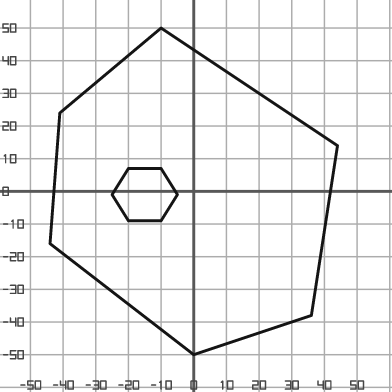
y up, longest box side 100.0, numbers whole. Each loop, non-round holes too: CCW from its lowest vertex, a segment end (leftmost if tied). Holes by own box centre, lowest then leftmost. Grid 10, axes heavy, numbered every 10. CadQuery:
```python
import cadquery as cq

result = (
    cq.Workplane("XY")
    .moveTo(0.0, -50.0)
    .lineTo(36.0, -38.0)
    .lineTo(44.0, 14.0)
    .lineTo(-10.0, 50.0)
    .lineTo(-41.0, 24.0)
    .lineTo(-44.0, -16.0)
    .close()
    .moveTo(-20.0, -9.0)
    .lineTo(-10.0, -9.0)
    .lineTo(-5.0, -1.0)
    .lineTo(-10.0, 7.0)
    .lineTo(-20.0, 7.0)
    .lineTo(-25.0, -1.0)
    .close()
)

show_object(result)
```